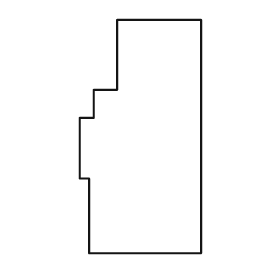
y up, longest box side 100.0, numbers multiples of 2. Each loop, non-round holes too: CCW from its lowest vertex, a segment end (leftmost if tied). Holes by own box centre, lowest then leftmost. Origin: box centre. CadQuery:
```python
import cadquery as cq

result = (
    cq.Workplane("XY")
    .moveTo(-22.0, -50.0)
    .lineTo(26.0, -50.0)
    .lineTo(26.0, 50.0)
    .lineTo(-10.0, 50.0)
    .lineTo(-10.0, 20.0)
    .lineTo(-20.0, 20.0)
    .lineTo(-20.0, 8.0)
    .lineTo(-26.0, 8.0)
    .lineTo(-26.0, -18.0)
    .lineTo(-22.0, -18.0)
    .close()
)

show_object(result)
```